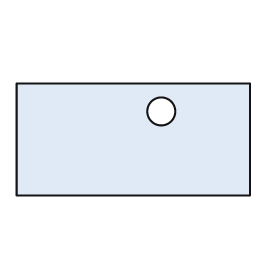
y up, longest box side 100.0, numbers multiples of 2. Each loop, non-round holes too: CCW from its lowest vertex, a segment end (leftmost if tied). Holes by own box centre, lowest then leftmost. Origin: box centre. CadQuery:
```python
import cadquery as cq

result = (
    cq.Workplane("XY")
    .moveTo(-50.0, -24.0)
    .lineTo(50.0, -24.0)
    .lineTo(50.0, 24.0)
    .lineTo(-50.0, 24.0)
    .close()
    .moveTo(12.0, 12.0)
    .circle(6.0)
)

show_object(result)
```